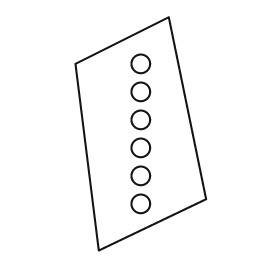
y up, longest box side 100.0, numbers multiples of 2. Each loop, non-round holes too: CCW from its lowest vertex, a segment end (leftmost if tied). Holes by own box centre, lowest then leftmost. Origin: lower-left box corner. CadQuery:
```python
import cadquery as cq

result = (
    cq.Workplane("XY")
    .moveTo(10.0, 0.0)
    .lineTo(56.0, 22.0)
    .lineTo(40.0, 100.0)
    .lineTo(0.0, 80.0)
    .close()
    .moveTo(28.0, 20.0)
    .circle(4.0)
    .moveTo(28.0, 32.0)
    .circle(4.0)
    .moveTo(28.0, 44.0)
    .circle(4.0)
    .moveTo(28.0, 56.0)
    .circle(4.0)
    .moveTo(28.0, 68.0)
    .circle(4.0)
    .moveTo(28.0, 80.0)
    .circle(4.0)
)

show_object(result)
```